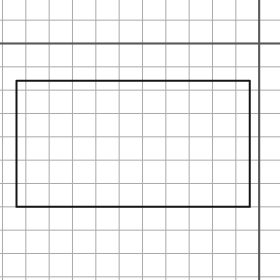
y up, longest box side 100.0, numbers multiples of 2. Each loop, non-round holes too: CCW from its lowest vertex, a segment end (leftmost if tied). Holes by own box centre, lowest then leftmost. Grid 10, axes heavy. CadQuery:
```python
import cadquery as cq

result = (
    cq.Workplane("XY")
    .moveTo(-104.0, -70.0)
    .lineTo(-4.0, -70.0)
    .lineTo(-4.0, -16.0)
    .lineTo(-104.0, -16.0)
    .close()
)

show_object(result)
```